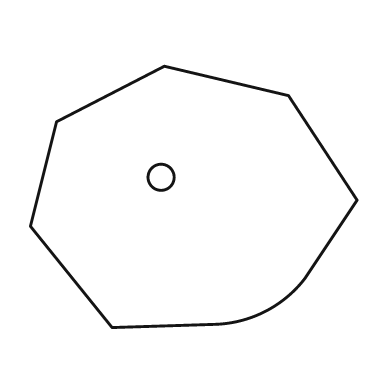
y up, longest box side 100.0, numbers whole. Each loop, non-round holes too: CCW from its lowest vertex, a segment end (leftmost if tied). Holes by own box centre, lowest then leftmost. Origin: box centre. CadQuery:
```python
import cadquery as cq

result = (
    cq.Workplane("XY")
    .moveTo(-25.0, -40.0)
    .lineTo(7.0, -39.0)
    .threePointArc((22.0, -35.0), (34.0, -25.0))
    .lineTo(50.0, -1.0)
    .lineTo(29.0, 31.0)
    .lineTo(-9.0, 40.0)
    .lineTo(-42.0, 23.0)
    .lineTo(-50.0, -9.0)
    .close()
    .moveTo(-10.0, 6.0)
    .circle(4.0)
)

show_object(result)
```